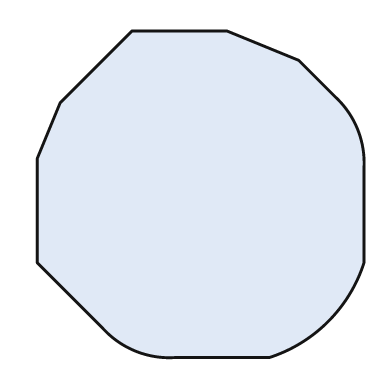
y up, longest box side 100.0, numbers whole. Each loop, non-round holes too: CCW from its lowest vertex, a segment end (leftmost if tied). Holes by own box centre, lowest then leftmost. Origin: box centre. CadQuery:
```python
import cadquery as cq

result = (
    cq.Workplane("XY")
    .moveTo(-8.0, -50.0)
    .lineTo(21.0, -50.0)
    .threePointArc((39.0, -39.0), (50.0, -21.0))
    .lineTo(50.0, 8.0)
    .threePointArc((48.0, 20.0), (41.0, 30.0))
    .lineTo(30.0, 41.0)
    .lineTo(8.0, 50.0)
    .lineTo(-21.0, 50.0)
    .lineTo(-43.0, 28.0)
    .lineTo(-50.0, 11.0)
    .lineTo(-50.0, -21.0)
    .lineTo(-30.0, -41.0)
    .threePointArc((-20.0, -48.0), (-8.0, -50.0))
    .close()
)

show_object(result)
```